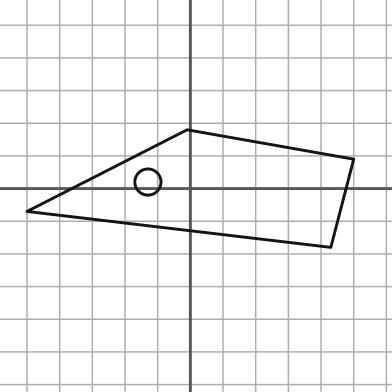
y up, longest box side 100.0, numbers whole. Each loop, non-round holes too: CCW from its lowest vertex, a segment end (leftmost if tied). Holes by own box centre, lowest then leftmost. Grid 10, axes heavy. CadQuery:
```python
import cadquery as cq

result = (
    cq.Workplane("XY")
    .moveTo(43.0, -18.0)
    .lineTo(50.0, 9.0)
    .lineTo(-1.0, 18.0)
    .lineTo(-50.0, -7.0)
    .close()
    .moveTo(-13.0, 2.0)
    .circle(4.0)
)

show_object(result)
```